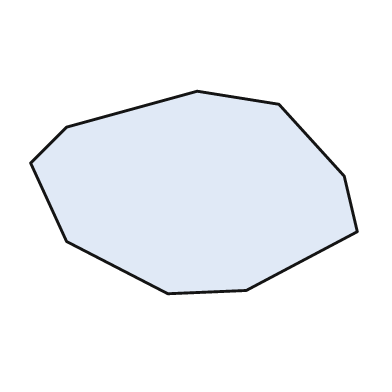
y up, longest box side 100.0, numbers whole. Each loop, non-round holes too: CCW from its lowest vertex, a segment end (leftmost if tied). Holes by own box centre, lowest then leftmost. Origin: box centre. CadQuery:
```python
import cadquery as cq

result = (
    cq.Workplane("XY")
    .moveTo(-8.0, -31.0)
    .lineTo(16.0, -30.0)
    .lineTo(50.0, -12.0)
    .lineTo(46.0, 5.0)
    .lineTo(26.0, 27.0)
    .lineTo(1.0, 31.0)
    .lineTo(-39.0, 20.0)
    .lineTo(-50.0, 9.0)
    .lineTo(-39.0, -15.0)
    .close()
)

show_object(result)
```